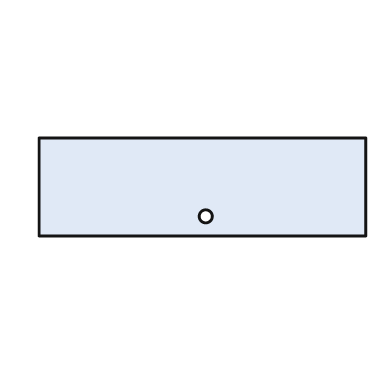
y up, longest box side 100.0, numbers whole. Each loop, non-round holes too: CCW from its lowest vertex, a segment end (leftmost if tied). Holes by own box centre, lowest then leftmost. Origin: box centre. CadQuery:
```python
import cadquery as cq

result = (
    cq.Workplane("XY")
    .moveTo(-50.0, -15.0)
    .lineTo(50.0, -15.0)
    .lineTo(50.0, 15.0)
    .lineTo(-50.0, 15.0)
    .close()
    .moveTo(1.0, -9.0)
    .circle(2.0)
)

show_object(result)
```